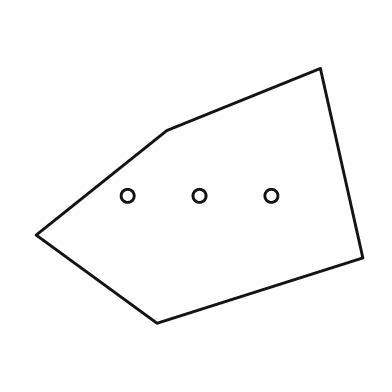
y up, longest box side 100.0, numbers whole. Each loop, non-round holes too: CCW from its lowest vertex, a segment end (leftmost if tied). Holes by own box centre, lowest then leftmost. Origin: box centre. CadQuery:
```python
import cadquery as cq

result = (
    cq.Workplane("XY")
    .moveTo(-13.0, -39.0)
    .lineTo(50.0, -19.0)
    .lineTo(37.0, 39.0)
    .lineTo(-10.0, 20.0)
    .lineTo(-50.0, -12.0)
    .close()
    .moveTo(-22.0, 0.0)
    .circle(2.0)
    .moveTo(0.0, 0.0)
    .circle(2.0)
    .moveTo(22.0, 0.0)
    .circle(2.0)
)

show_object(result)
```